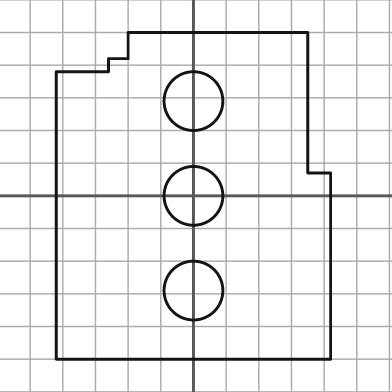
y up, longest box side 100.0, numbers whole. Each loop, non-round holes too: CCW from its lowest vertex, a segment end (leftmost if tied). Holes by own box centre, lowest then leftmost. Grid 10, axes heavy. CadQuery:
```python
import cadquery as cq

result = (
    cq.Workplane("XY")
    .moveTo(-42.0, -50.0)
    .lineTo(42.0, -50.0)
    .lineTo(42.0, 7.0)
    .lineTo(35.0, 7.0)
    .lineTo(35.0, 50.0)
    .lineTo(-20.0, 50.0)
    .lineTo(-20.0, 42.0)
    .lineTo(-26.0, 42.0)
    .lineTo(-26.0, 38.0)
    .lineTo(-42.0, 38.0)
    .close()
    .moveTo(0.0, -29.0)
    .circle(9.0)
    .moveTo(0.0, 0.0)
    .circle(9.0)
    .moveTo(0.0, 29.0)
    .circle(9.0)
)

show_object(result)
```